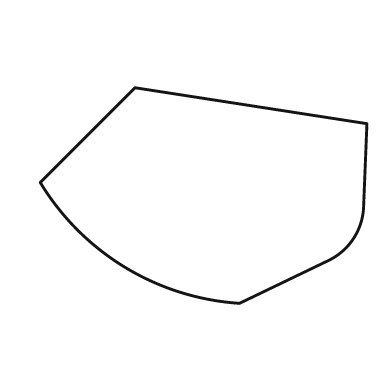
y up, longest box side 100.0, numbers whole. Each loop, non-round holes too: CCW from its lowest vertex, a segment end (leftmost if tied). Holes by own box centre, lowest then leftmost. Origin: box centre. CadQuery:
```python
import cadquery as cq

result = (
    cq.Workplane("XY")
    .moveTo(11.0, -33.0)
    .lineTo(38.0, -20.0)
    .threePointArc((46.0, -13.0), (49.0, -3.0))
    .lineTo(50.0, 22.0)
    .lineTo(-21.0, 33.0)
    .lineTo(-50.0, 4.0)
    .threePointArc((-24.0, -22.0), (11.0, -33.0))
    .close()
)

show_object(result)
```